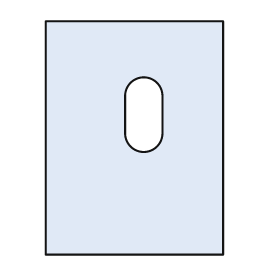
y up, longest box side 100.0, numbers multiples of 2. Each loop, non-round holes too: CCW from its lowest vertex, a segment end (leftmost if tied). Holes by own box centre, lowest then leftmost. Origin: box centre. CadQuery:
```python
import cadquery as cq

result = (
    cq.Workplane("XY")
    .moveTo(-38.0, -50.0)
    .lineTo(38.0, -50.0)
    .lineTo(38.0, 50.0)
    .lineTo(-38.0, 50.0)
    .close()
    .moveTo(-4.0, 2.0)
    .threePointArc((4.0, -6.0), (12.0, 2.0))
    .lineTo(12.0, 18.0)
    .threePointArc((4.0, 26.0), (-4.0, 18.0))
    .close()
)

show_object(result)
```